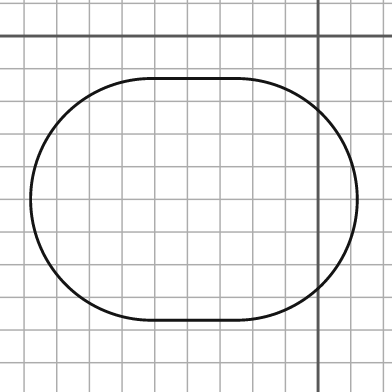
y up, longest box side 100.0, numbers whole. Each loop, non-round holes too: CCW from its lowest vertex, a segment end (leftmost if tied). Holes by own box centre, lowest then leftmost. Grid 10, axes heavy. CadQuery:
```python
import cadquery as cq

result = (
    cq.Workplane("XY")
    .moveTo(-51.0, -87.0)
    .lineTo(-25.0, -87.0)
    .threePointArc((12.0, -50.0), (-25.0, -13.0))
    .lineTo(-51.0, -13.0)
    .threePointArc((-88.0, -50.0), (-51.0, -87.0))
    .close()
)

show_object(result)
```